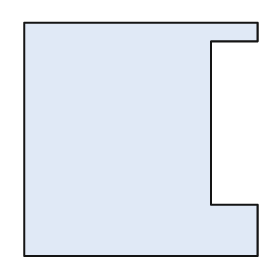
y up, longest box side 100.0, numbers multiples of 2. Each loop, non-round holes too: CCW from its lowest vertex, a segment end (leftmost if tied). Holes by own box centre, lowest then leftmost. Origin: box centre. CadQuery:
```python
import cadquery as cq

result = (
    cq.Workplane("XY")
    .moveTo(-50.0, -50.0)
    .lineTo(50.0, -50.0)
    .lineTo(50.0, -28.0)
    .lineTo(30.0, -28.0)
    .lineTo(30.0, 42.0)
    .lineTo(50.0, 42.0)
    .lineTo(50.0, 50.0)
    .lineTo(-50.0, 50.0)
    .close()
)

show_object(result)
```